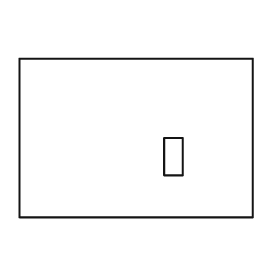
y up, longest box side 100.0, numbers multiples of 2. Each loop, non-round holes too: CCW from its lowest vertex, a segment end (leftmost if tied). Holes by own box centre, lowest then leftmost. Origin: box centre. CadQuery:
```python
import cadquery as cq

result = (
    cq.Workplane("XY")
    .moveTo(-50.0, -34.0)
    .lineTo(50.0, -34.0)
    .lineTo(50.0, 34.0)
    .lineTo(-50.0, 34.0)
    .close()
    .moveTo(12.0, -16.0)
    .lineTo(20.0, -16.0)
    .lineTo(20.0, 0.0)
    .lineTo(12.0, 0.0)
    .close()
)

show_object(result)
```